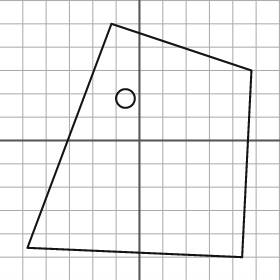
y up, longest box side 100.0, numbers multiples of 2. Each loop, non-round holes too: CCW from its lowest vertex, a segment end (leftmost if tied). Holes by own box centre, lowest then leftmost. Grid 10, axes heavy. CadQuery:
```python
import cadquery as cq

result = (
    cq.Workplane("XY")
    .moveTo(44.0, -50.0)
    .lineTo(48.0, 30.0)
    .lineTo(-12.0, 50.0)
    .lineTo(-48.0, -46.0)
    .close()
    .moveTo(-6.0, 18.0)
    .circle(4.0)
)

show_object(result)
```